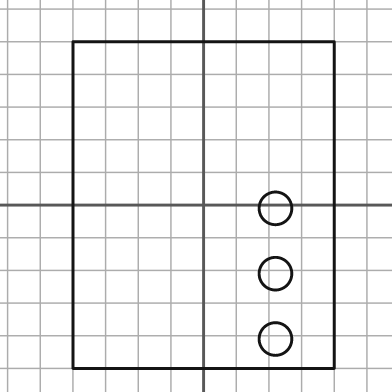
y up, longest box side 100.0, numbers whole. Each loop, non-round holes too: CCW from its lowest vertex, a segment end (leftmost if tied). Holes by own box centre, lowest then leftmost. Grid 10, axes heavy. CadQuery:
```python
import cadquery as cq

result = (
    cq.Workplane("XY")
    .moveTo(-40.0, -50.0)
    .lineTo(40.0, -50.0)
    .lineTo(40.0, 50.0)
    .lineTo(-40.0, 50.0)
    .close()
    .moveTo(22.0, -41.0)
    .circle(5.0)
    .moveTo(22.0, -21.0)
    .circle(5.0)
    .moveTo(22.0, -1.0)
    .circle(5.0)
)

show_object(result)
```